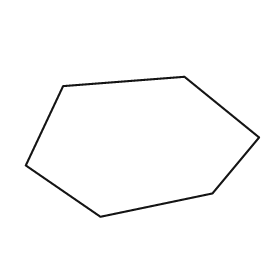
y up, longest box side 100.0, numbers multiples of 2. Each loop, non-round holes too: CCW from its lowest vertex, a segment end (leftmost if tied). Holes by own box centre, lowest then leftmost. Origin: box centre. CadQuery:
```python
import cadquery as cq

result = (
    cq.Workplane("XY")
    .moveTo(-18.0, -30.0)
    .lineTo(30.0, -20.0)
    .lineTo(50.0, 4.0)
    .lineTo(18.0, 30.0)
    .lineTo(-34.0, 26.0)
    .lineTo(-50.0, -8.0)
    .close()
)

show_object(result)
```